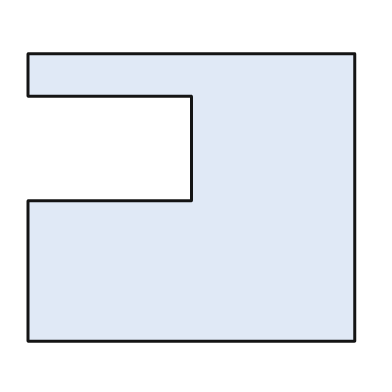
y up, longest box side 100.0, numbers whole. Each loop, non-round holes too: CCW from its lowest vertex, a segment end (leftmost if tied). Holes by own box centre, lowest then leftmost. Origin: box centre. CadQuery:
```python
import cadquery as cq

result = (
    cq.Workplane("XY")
    .moveTo(-50.0, -44.0)
    .lineTo(50.0, -44.0)
    .lineTo(50.0, 44.0)
    .lineTo(-50.0, 44.0)
    .lineTo(-50.0, 31.0)
    .lineTo(0.0, 31.0)
    .lineTo(0.0, -1.0)
    .lineTo(-50.0, -1.0)
    .close()
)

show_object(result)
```